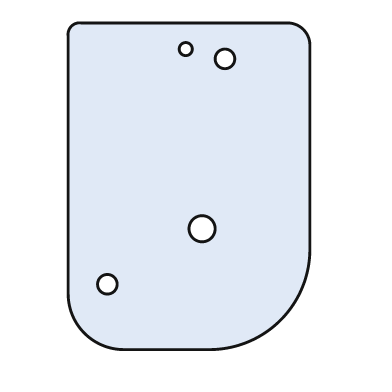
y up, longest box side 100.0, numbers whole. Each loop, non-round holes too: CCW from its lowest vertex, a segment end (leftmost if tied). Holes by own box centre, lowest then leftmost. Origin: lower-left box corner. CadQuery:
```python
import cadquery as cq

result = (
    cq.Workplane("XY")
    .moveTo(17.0, 0.0)
    .lineTo(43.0, 0.0)
    .threePointArc((65.0, 9.0), (74.0, 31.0))
    .lineTo(74.0, 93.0)
    .threePointArc((72.0, 98.0), (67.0, 100.0))
    .lineTo(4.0, 100.0)
    .threePointArc((1.0, 99.0), (0.0, 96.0))
    .lineTo(0.0, 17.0)
    .threePointArc((5.0, 5.0), (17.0, 0.0))
    .close()
    .moveTo(12.0, 20.0)
    .circle(3.0)
    .moveTo(41.0, 37.0)
    .circle(4.0)
    .moveTo(48.0, 89.0)
    .circle(3.0)
    .moveTo(36.0, 92.0)
    .circle(2.0)
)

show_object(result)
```